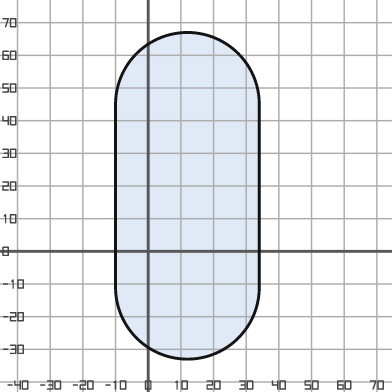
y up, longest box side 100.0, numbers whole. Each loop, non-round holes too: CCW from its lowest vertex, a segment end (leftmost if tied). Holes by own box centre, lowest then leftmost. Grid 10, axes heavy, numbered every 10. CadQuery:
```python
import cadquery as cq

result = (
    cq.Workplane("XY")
    .moveTo(-10.0, -11.0)
    .threePointArc((12.0, -33.0), (34.0, -11.0))
    .lineTo(34.0, 45.0)
    .threePointArc((12.0, 67.0), (-10.0, 45.0))
    .close()
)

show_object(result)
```